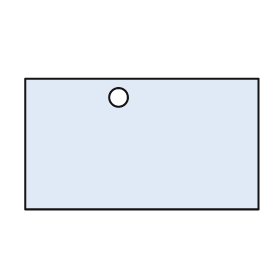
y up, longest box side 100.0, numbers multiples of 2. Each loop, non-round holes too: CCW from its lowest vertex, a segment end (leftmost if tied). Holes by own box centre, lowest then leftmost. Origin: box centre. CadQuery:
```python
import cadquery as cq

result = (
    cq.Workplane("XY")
    .moveTo(-50.0, -28.0)
    .lineTo(50.0, -28.0)
    .lineTo(50.0, 28.0)
    .lineTo(-50.0, 28.0)
    .close()
    .moveTo(-10.0, 20.0)
    .circle(4.0)
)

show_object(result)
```